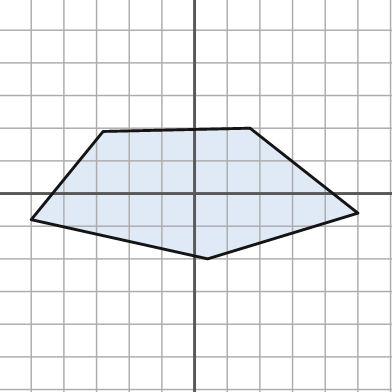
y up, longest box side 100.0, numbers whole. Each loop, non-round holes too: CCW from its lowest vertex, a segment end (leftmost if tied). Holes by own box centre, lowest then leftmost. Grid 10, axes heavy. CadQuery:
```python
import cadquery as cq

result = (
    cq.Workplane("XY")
    .moveTo(4.0, -20.0)
    .lineTo(50.0, -6.0)
    .lineTo(17.0, 20.0)
    .lineTo(-28.0, 19.0)
    .lineTo(-50.0, -8.0)
    .close()
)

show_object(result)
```